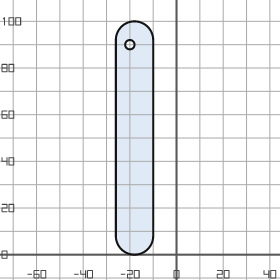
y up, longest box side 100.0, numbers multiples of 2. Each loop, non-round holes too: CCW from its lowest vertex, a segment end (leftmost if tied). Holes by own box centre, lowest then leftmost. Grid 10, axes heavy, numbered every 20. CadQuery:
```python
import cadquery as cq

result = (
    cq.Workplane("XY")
    .moveTo(-26.0, 8.0)
    .threePointArc((-18.0, 0.0), (-10.0, 8.0))
    .lineTo(-10.0, 92.0)
    .threePointArc((-18.0, 100.0), (-26.0, 92.0))
    .close()
    .moveTo(-20.0, 90.0)
    .circle(2.0)
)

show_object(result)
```